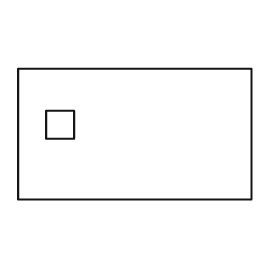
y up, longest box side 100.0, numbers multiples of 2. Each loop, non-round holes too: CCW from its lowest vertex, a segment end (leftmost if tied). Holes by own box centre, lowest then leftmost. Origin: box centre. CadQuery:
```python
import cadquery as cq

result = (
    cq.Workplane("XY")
    .moveTo(-50.0, -28.0)
    .lineTo(50.0, -28.0)
    .lineTo(50.0, 28.0)
    .lineTo(-50.0, 28.0)
    .close()
    .moveTo(-38.0, -2.0)
    .lineTo(-26.0, -2.0)
    .lineTo(-26.0, 10.0)
    .lineTo(-38.0, 10.0)
    .close()
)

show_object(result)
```